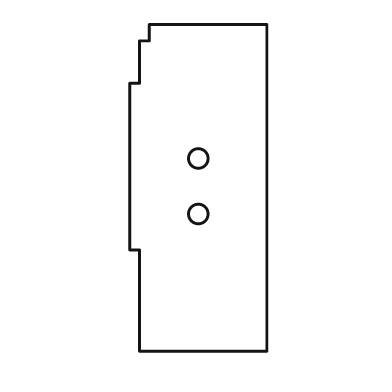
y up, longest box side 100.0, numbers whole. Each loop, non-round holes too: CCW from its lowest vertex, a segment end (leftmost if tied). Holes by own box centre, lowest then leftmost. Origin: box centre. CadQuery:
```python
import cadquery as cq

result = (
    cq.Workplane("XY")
    .moveTo(-18.0, -50.0)
    .lineTo(21.0, -50.0)
    .lineTo(21.0, 50.0)
    .lineTo(-15.0, 50.0)
    .lineTo(-15.0, 45.0)
    .lineTo(-18.0, 45.0)
    .lineTo(-18.0, 32.0)
    .lineTo(-21.0, 32.0)
    .lineTo(-21.0, -19.0)
    .lineTo(-18.0, -19.0)
    .close()
    .moveTo(0.0, -8.0)
    .circle(3.0)
    .moveTo(0.0, 9.0)
    .circle(3.0)
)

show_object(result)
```